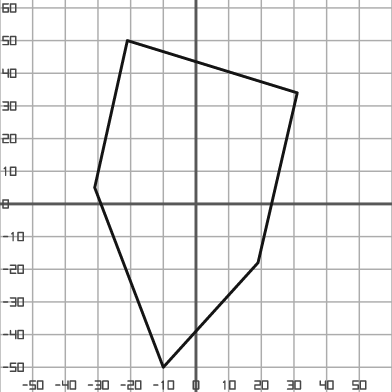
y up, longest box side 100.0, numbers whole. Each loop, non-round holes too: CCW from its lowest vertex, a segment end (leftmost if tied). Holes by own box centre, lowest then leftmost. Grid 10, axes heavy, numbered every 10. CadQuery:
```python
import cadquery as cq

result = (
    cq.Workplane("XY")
    .moveTo(-10.0, -50.0)
    .lineTo(19.0, -18.0)
    .lineTo(31.0, 34.0)
    .lineTo(-21.0, 50.0)
    .lineTo(-31.0, 5.0)
    .close()
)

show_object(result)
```